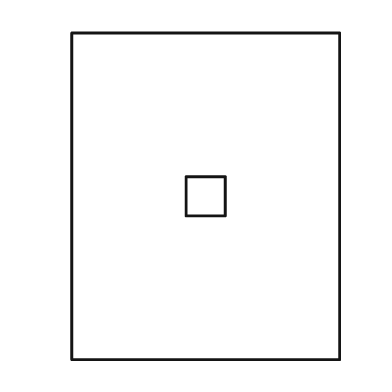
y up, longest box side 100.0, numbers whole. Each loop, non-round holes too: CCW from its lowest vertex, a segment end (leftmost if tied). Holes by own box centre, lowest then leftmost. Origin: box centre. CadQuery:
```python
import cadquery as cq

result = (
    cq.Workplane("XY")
    .moveTo(-41.0, -50.0)
    .lineTo(41.0, -50.0)
    .lineTo(41.0, 50.0)
    .lineTo(-41.0, 50.0)
    .close()
    .moveTo(-6.0, -6.0)
    .lineTo(6.0, -6.0)
    .lineTo(6.0, 6.0)
    .lineTo(-6.0, 6.0)
    .close()
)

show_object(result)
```